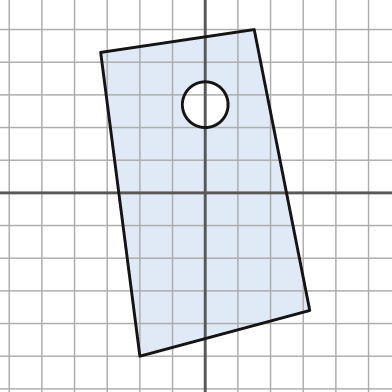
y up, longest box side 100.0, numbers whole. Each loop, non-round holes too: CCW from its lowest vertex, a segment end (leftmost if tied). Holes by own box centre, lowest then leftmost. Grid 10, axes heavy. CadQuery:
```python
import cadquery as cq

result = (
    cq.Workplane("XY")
    .moveTo(-20.0, -50.0)
    .lineTo(32.0, -36.0)
    .lineTo(15.0, 50.0)
    .lineTo(-32.0, 43.0)
    .close()
    .moveTo(0.0, 27.0)
    .circle(7.0)
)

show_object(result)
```